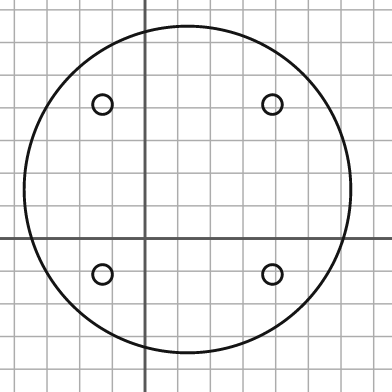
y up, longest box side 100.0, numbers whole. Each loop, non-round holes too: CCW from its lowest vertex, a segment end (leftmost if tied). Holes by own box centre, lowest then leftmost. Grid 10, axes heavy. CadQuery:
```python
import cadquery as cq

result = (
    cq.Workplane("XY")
    .moveTo(13.0, 15.0)
    .circle(50.0)
    .moveTo(-13.0, -11.0)
    .circle(3.0)
    .moveTo(39.0, -11.0)
    .circle(3.0)
    .moveTo(-13.0, 41.0)
    .circle(3.0)
    .moveTo(39.0, 41.0)
    .circle(3.0)
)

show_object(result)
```